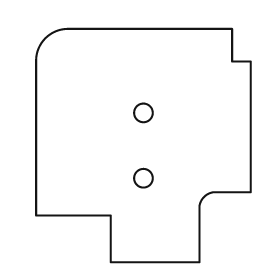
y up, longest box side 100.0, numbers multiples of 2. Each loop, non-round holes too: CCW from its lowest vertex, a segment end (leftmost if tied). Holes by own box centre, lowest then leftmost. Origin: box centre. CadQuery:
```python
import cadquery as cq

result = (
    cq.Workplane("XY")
    .moveTo(-14.0, -50.0)
    .lineTo(24.0, -50.0)
    .lineTo(24.0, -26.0)
    .threePointArc((26.0, -22.0), (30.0, -20.0))
    .lineTo(46.0, -20.0)
    .lineTo(46.0, 36.0)
    .lineTo(38.0, 36.0)
    .lineTo(38.0, 50.0)
    .lineTo(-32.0, 50.0)
    .threePointArc((-42.0, 46.0), (-46.0, 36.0))
    .lineTo(-46.0, -30.0)
    .lineTo(-14.0, -30.0)
    .close()
    .moveTo(0.0, -14.0)
    .circle(4.0)
    .moveTo(0.0, 14.0)
    .circle(4.0)
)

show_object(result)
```